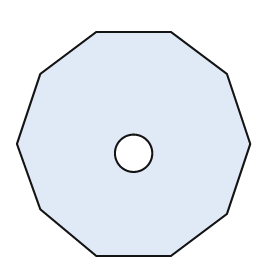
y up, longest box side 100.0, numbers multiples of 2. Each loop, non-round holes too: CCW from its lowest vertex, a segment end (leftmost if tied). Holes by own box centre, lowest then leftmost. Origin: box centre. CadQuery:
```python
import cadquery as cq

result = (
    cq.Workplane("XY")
    .moveTo(-16.0, -48.0)
    .lineTo(16.0, -48.0)
    .lineTo(40.0, -30.0)
    .lineTo(50.0, 0.0)
    .lineTo(40.0, 30.0)
    .lineTo(16.0, 48.0)
    .lineTo(-16.0, 48.0)
    .lineTo(-40.0, 30.0)
    .lineTo(-50.0, 0.0)
    .lineTo(-40.0, -28.0)
    .close()
    .moveTo(0.0, -4.0)
    .circle(8.0)
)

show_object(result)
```